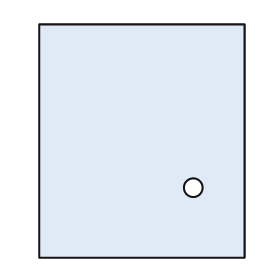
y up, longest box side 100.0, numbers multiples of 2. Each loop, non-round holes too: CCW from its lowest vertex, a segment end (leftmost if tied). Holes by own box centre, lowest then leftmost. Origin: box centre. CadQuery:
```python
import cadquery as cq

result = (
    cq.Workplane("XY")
    .moveTo(-44.0, -50.0)
    .lineTo(44.0, -50.0)
    .lineTo(44.0, 50.0)
    .lineTo(-44.0, 50.0)
    .close()
    .moveTo(22.0, -20.0)
    .circle(4.0)
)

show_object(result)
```